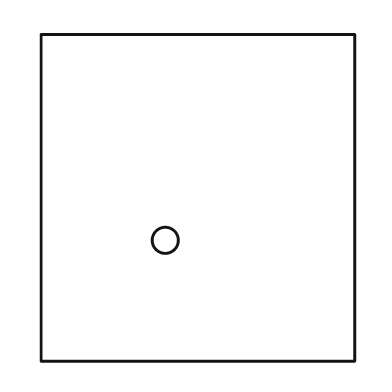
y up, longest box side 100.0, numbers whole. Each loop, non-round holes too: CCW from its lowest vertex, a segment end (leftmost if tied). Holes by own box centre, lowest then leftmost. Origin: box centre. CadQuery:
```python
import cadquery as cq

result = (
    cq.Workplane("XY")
    .moveTo(-48.0, -50.0)
    .lineTo(48.0, -50.0)
    .lineTo(48.0, 50.0)
    .lineTo(-48.0, 50.0)
    .close()
    .moveTo(-10.0, -13.0)
    .circle(4.0)
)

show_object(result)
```